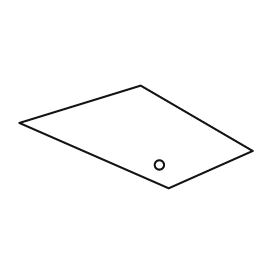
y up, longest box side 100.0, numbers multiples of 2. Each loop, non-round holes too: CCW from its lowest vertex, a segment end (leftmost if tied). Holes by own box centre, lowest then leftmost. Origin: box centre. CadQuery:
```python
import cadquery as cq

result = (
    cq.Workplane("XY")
    .moveTo(14.0, -22.0)
    .lineTo(50.0, -6.0)
    .lineTo(2.0, 22.0)
    .lineTo(-50.0, 6.0)
    .close()
    .moveTo(10.0, -12.0)
    .circle(2.0)
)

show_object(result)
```